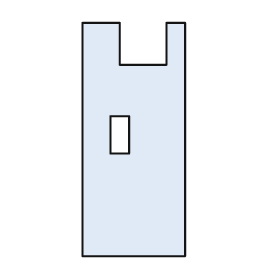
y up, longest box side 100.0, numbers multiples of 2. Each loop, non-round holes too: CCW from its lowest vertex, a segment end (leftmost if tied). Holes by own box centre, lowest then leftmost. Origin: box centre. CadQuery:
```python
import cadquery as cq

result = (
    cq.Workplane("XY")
    .moveTo(-22.0, -50.0)
    .lineTo(22.0, -50.0)
    .lineTo(22.0, 50.0)
    .lineTo(14.0, 50.0)
    .lineTo(14.0, 32.0)
    .lineTo(-6.0, 32.0)
    .lineTo(-6.0, 50.0)
    .lineTo(-22.0, 50.0)
    .close()
    .moveTo(-10.0, -6.0)
    .lineTo(-2.0, -6.0)
    .lineTo(-2.0, 10.0)
    .lineTo(-10.0, 10.0)
    .close()
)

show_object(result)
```